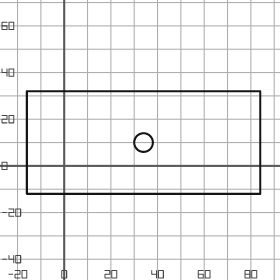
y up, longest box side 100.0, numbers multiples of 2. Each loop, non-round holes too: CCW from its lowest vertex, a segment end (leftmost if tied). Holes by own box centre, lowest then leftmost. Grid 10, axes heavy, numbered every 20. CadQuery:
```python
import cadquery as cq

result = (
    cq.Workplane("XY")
    .moveTo(-16.0, -12.0)
    .lineTo(84.0, -12.0)
    .lineTo(84.0, 32.0)
    .lineTo(-16.0, 32.0)
    .close()
    .moveTo(34.0, 10.0)
    .circle(4.0)
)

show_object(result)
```